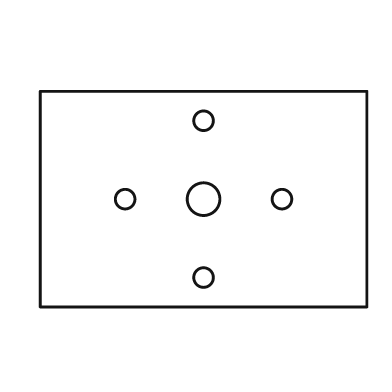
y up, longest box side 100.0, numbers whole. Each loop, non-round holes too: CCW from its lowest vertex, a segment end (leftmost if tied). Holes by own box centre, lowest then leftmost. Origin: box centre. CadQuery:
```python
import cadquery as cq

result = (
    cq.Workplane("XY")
    .moveTo(-50.0, -33.0)
    .lineTo(50.0, -33.0)
    .lineTo(50.0, 33.0)
    .lineTo(-50.0, 33.0)
    .close()
    .moveTo(0.0, -24.0)
    .circle(3.0)
    .moveTo(-24.0, 0.0)
    .circle(3.0)
    .moveTo(0.0, 0.0)
    .circle(5.0)
    .moveTo(24.0, 0.0)
    .circle(3.0)
    .moveTo(0.0, 24.0)
    .circle(3.0)
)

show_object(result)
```